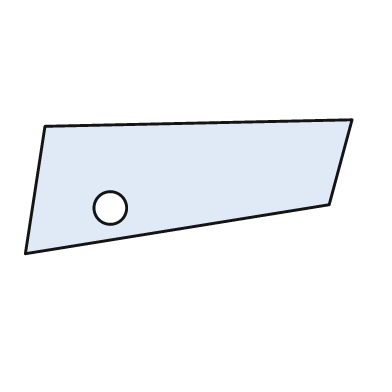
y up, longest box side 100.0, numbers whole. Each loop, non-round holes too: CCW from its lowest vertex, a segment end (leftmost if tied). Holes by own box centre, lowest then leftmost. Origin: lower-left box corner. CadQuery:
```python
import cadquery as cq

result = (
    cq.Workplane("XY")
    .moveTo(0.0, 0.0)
    .lineTo(93.0, 15.0)
    .lineTo(100.0, 41.0)
    .lineTo(6.0, 39.0)
    .close()
    .moveTo(26.0, 14.0)
    .circle(5.0)
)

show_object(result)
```